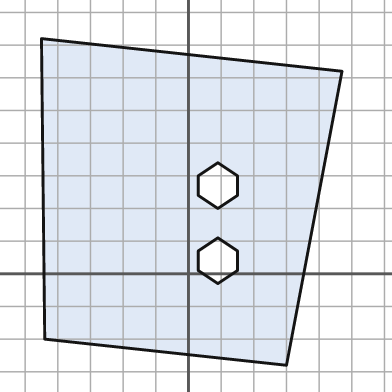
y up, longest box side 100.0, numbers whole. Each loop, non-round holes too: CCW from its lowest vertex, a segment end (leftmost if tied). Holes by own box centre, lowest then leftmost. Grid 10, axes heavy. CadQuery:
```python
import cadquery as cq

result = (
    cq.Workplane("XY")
    .moveTo(30.0, -28.0)
    .lineTo(47.0, 62.0)
    .lineTo(-45.0, 72.0)
    .lineTo(-44.0, -20.0)
    .close()
    .moveTo(9.0, -3.0)
    .lineTo(15.0, 1.0)
    .lineTo(15.0, 7.0)
    .lineTo(9.0, 11.0)
    .lineTo(3.0, 7.0)
    .lineTo(3.0, 1.0)
    .close()
    .moveTo(9.0, 20.0)
    .lineTo(15.0, 24.0)
    .lineTo(15.0, 30.0)
    .lineTo(9.0, 34.0)
    .lineTo(3.0, 30.0)
    .lineTo(3.0, 24.0)
    .close()
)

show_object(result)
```